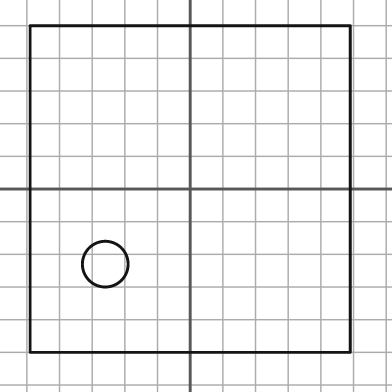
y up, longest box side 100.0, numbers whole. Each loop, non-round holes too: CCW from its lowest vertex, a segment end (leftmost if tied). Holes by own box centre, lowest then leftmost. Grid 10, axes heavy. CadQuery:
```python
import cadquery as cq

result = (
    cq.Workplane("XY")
    .moveTo(-49.0, -50.0)
    .lineTo(49.0, -50.0)
    .lineTo(49.0, 50.0)
    .lineTo(-49.0, 50.0)
    .close()
    .moveTo(-26.0, -23.0)
    .circle(7.0)
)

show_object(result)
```